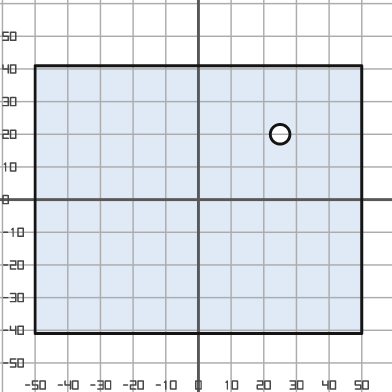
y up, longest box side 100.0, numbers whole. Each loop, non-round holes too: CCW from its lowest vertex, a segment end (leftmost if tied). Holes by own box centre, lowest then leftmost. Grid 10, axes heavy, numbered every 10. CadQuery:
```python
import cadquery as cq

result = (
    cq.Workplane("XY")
    .moveTo(-50.0, -41.0)
    .lineTo(50.0, -41.0)
    .lineTo(50.0, 41.0)
    .lineTo(-50.0, 41.0)
    .close()
    .moveTo(25.0, 20.0)
    .circle(3.0)
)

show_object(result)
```